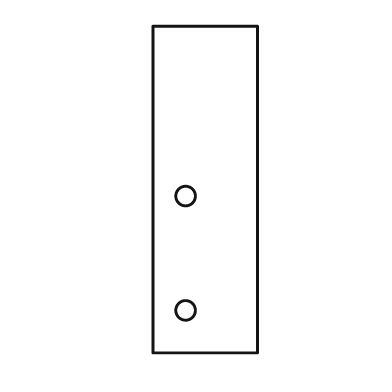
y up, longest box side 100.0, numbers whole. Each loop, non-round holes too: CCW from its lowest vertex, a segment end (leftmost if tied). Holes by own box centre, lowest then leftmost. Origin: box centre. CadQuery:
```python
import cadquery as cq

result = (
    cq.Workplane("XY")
    .moveTo(-16.0, -50.0)
    .lineTo(16.0, -50.0)
    .lineTo(16.0, 50.0)
    .lineTo(-16.0, 50.0)
    .close()
    .moveTo(-6.0, -37.0)
    .circle(3.0)
    .moveTo(-6.0, -2.0)
    .circle(3.0)
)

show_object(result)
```